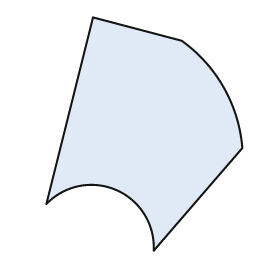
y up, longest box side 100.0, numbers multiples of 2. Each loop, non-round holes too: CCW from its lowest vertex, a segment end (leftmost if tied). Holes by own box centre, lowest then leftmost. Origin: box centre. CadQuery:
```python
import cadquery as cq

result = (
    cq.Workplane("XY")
    .moveTo(4.0, -50.0)
    .lineTo(42.0, -6.0)
    .threePointArc((34.0, 20.0), (16.0, 40.0))
    .lineTo(-22.0, 50.0)
    .lineTo(-42.0, -30.0)
    .threePointArc((-12.0, -24.0), (4.0, -50.0))
    .close()
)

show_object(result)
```